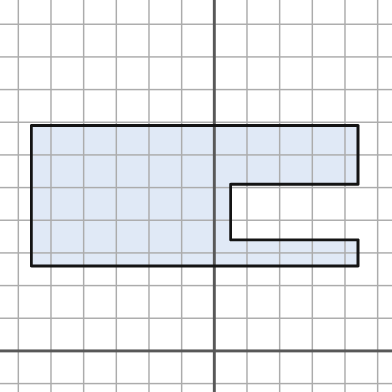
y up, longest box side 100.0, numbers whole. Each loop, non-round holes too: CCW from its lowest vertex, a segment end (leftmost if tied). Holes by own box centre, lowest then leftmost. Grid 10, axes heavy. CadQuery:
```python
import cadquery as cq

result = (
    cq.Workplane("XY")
    .moveTo(-56.0, 26.0)
    .lineTo(44.0, 26.0)
    .lineTo(44.0, 34.0)
    .lineTo(5.0, 34.0)
    .lineTo(5.0, 51.0)
    .lineTo(44.0, 51.0)
    .lineTo(44.0, 69.0)
    .lineTo(-56.0, 69.0)
    .close()
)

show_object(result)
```